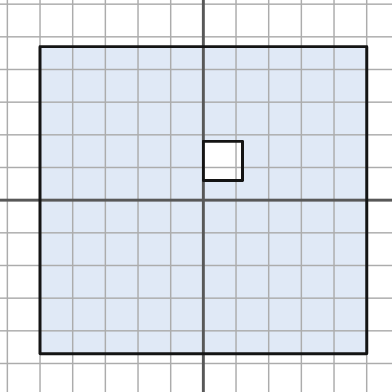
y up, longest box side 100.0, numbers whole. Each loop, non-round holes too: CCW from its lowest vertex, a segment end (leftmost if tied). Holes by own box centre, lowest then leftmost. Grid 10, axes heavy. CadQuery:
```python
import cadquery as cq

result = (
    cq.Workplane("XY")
    .moveTo(-50.0, -47.0)
    .lineTo(50.0, -47.0)
    .lineTo(50.0, 47.0)
    .lineTo(-50.0, 47.0)
    .close()
    .moveTo(0.0, 6.0)
    .lineTo(12.0, 6.0)
    .lineTo(12.0, 18.0)
    .lineTo(0.0, 18.0)
    .close()
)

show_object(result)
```